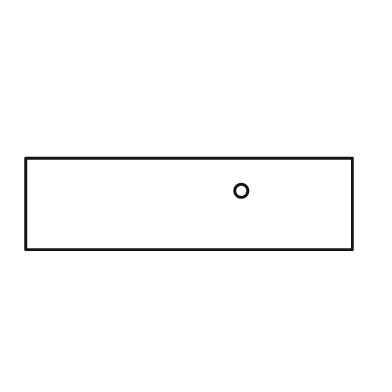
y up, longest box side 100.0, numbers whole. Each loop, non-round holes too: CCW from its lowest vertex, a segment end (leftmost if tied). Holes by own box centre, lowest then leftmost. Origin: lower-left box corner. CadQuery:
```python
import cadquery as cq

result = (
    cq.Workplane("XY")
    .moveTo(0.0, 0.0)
    .lineTo(100.0, 0.0)
    .lineTo(100.0, 28.0)
    .lineTo(0.0, 28.0)
    .close()
    .moveTo(66.0, 18.0)
    .circle(2.0)
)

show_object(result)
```